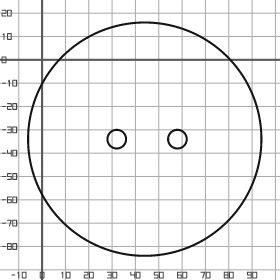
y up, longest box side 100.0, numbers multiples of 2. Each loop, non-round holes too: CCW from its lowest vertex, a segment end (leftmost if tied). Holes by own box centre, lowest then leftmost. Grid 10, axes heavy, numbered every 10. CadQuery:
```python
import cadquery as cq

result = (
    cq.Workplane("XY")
    .moveTo(44.0, -34.0)
    .circle(50.0)
    .moveTo(32.0, -34.0)
    .circle(4.0)
    .moveTo(58.0, -34.0)
    .circle(4.0)
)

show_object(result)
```